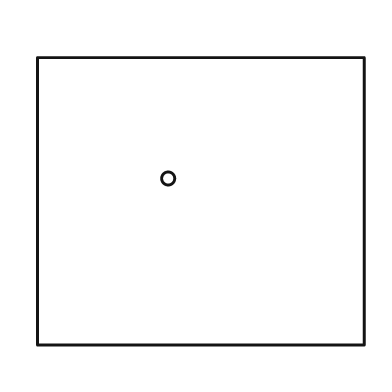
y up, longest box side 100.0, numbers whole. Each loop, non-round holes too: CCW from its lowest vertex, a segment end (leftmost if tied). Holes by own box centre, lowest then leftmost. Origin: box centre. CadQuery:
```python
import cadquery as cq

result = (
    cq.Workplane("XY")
    .moveTo(-50.0, -44.0)
    .lineTo(50.0, -44.0)
    .lineTo(50.0, 44.0)
    .lineTo(-50.0, 44.0)
    .close()
    .moveTo(-10.0, 7.0)
    .circle(2.0)
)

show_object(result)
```